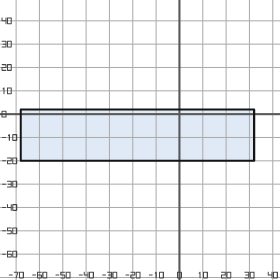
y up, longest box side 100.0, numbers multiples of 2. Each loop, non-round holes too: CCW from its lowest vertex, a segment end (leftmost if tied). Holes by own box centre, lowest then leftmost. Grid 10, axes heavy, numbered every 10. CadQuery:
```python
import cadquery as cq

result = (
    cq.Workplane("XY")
    .moveTo(-68.0, -20.0)
    .lineTo(32.0, -20.0)
    .lineTo(32.0, 2.0)
    .lineTo(-68.0, 2.0)
    .close()
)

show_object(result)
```